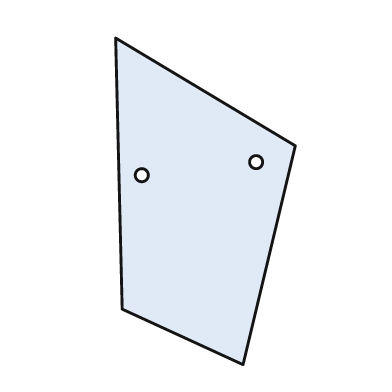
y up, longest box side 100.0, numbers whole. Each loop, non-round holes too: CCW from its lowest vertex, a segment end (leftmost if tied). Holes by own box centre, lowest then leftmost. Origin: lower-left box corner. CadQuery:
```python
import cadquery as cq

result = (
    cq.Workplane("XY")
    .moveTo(39.0, 0.0)
    .lineTo(55.0, 67.0)
    .lineTo(0.0, 100.0)
    .lineTo(2.0, 17.0)
    .close()
    .moveTo(8.0, 58.0)
    .circle(2.0)
    .moveTo(43.0, 62.0)
    .circle(2.0)
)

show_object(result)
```